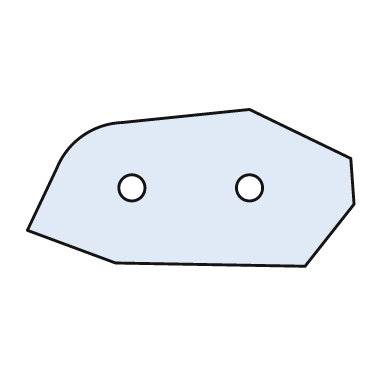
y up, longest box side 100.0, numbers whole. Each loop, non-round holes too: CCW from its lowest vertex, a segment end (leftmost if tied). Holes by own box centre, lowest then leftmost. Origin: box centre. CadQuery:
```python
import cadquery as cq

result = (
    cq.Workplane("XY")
    .moveTo(35.0, -24.0)
    .lineTo(50.0, -5.0)
    .lineTo(49.0, 9.0)
    .lineTo(18.0, 24.0)
    .lineTo(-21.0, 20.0)
    .threePointArc((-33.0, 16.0), (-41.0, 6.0))
    .lineTo(-50.0, -13.0)
    .lineTo(-23.0, -23.0)
    .close()
    .moveTo(-18.0, 0.0)
    .circle(4.0)
    .moveTo(18.0, 0.0)
    .circle(4.0)
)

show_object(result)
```